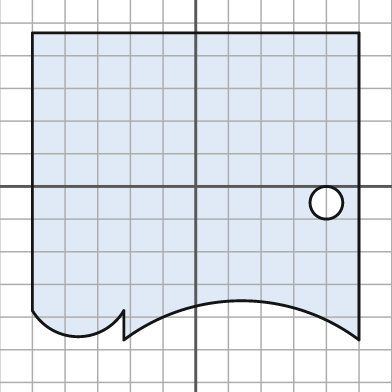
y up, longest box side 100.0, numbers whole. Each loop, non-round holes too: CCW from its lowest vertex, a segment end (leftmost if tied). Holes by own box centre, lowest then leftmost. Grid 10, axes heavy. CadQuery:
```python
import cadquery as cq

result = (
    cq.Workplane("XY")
    .moveTo(-22.0, -47.0)
    .threePointArc((14.0, -35.0), (50.0, -47.0))
    .lineTo(50.0, 47.0)
    .lineTo(-50.0, 47.0)
    .lineTo(-50.0, -38.0)
    .threePointArc((-36.0, -46.0), (-22.0, -38.0))
    .close()
    .moveTo(40.0, -5.0)
    .circle(5.0)
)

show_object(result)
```